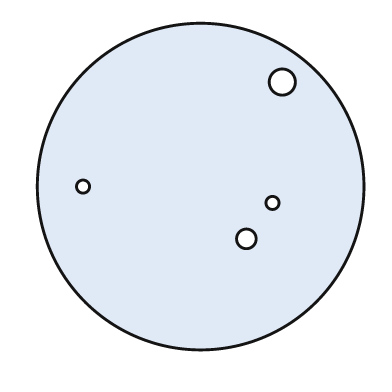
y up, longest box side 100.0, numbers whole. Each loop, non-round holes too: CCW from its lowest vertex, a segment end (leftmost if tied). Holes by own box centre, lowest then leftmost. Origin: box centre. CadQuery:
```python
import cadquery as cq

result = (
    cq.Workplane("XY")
    .moveTo(0.0, 0.0)
    .circle(50.0)
    .moveTo(14.0, -16.0)
    .circle(3.0)
    .moveTo(22.0, -5.0)
    .circle(2.0)
    .moveTo(-36.0, 0.0)
    .circle(2.0)
    .moveTo(25.0, 32.0)
    .circle(4.0)
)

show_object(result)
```